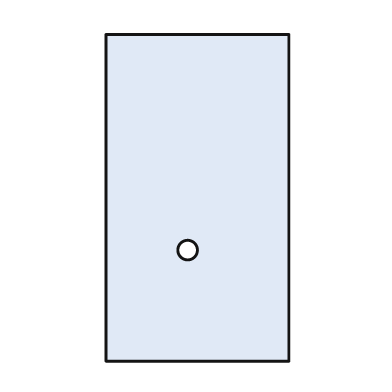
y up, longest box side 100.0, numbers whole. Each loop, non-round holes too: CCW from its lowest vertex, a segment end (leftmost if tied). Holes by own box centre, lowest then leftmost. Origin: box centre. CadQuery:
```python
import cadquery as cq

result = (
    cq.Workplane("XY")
    .moveTo(-28.0, -50.0)
    .lineTo(28.0, -50.0)
    .lineTo(28.0, 50.0)
    .lineTo(-28.0, 50.0)
    .close()
    .moveTo(-3.0, -16.0)
    .circle(3.0)
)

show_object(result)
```